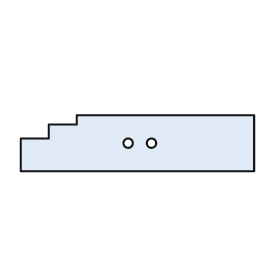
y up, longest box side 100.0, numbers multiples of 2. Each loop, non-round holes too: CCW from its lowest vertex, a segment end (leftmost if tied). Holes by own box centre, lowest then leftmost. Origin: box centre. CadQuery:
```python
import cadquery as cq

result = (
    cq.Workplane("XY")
    .moveTo(-50.0, -12.0)
    .lineTo(50.0, -12.0)
    .lineTo(50.0, 12.0)
    .lineTo(-26.0, 12.0)
    .lineTo(-26.0, 8.0)
    .lineTo(-38.0, 8.0)
    .lineTo(-38.0, 2.0)
    .lineTo(-50.0, 2.0)
    .close()
    .moveTo(-4.0, 0.0)
    .circle(2.0)
    .moveTo(6.0, 0.0)
    .circle(2.0)
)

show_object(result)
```